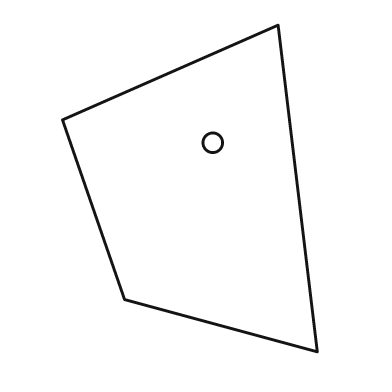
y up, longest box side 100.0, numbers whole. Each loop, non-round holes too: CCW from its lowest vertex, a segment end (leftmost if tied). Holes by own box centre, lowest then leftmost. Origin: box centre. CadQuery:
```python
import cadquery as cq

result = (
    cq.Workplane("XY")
    .moveTo(39.0, -50.0)
    .lineTo(27.0, 50.0)
    .lineTo(-39.0, 21.0)
    .lineTo(-20.0, -34.0)
    .close()
    .moveTo(7.0, 14.0)
    .circle(3.0)
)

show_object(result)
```